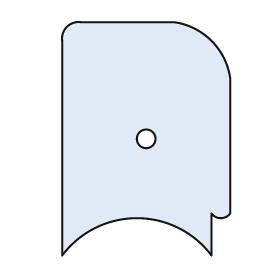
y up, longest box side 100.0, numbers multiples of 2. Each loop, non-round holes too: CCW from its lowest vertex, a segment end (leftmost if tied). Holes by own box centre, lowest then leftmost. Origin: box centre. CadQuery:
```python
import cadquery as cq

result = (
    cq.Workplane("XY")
    .moveTo(-36.0, -50.0)
    .threePointArc((-4.0, -34.0), (28.0, -50.0))
    .lineTo(28.0, -32.0)
    .threePointArc((32.0, -34.0), (36.0, -32.0))
    .lineTo(36.0, 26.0)
    .threePointArc((28.0, 42.0), (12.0, 50.0))
    .lineTo(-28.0, 50.0)
    .threePointArc((-34.0, 48.0), (-36.0, 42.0))
    .close()
    .moveTo(0.0, 0.0)
    .circle(4.0)
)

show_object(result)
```